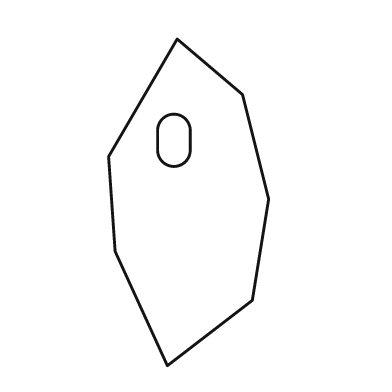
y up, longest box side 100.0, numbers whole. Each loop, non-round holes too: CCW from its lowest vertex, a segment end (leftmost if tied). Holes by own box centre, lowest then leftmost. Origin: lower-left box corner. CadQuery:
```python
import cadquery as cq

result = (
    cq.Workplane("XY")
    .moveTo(18.0, 0.0)
    .lineTo(44.0, 20.0)
    .lineTo(49.0, 51.0)
    .lineTo(41.0, 83.0)
    .lineTo(21.0, 100.0)
    .lineTo(0.0, 64.0)
    .lineTo(2.0, 35.0)
    .close()
    .moveTo(15.0, 66.0)
    .threePointArc((20.0, 61.0), (25.0, 66.0))
    .lineTo(25.0, 72.0)
    .threePointArc((20.0, 77.0), (15.0, 72.0))
    .close()
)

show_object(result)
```